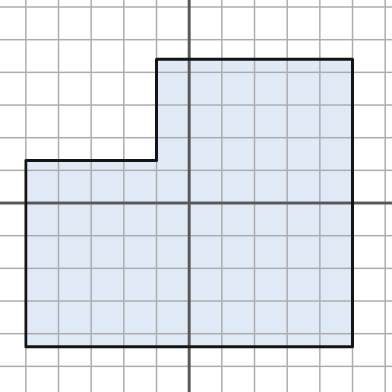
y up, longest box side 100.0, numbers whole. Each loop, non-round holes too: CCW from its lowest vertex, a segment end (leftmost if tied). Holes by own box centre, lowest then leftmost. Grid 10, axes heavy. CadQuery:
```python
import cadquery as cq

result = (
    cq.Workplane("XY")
    .moveTo(-50.0, -44.0)
    .lineTo(50.0, -44.0)
    .lineTo(50.0, 44.0)
    .lineTo(-10.0, 44.0)
    .lineTo(-10.0, 13.0)
    .lineTo(-50.0, 13.0)
    .close()
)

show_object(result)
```